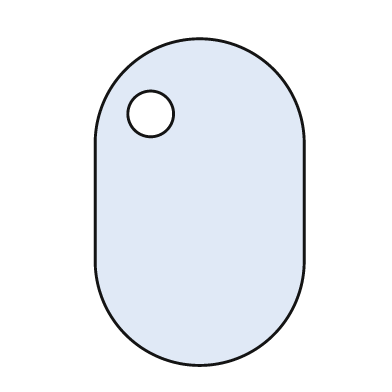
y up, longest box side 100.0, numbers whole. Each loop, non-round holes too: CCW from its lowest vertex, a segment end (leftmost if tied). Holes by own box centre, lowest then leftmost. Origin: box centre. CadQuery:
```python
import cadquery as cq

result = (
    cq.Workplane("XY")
    .moveTo(-32.0, -18.0)
    .threePointArc((0.0, -50.0), (32.0, -18.0))
    .lineTo(32.0, 18.0)
    .threePointArc((0.0, 50.0), (-32.0, 18.0))
    .close()
    .moveTo(-15.0, 27.0)
    .circle(7.0)
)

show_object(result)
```